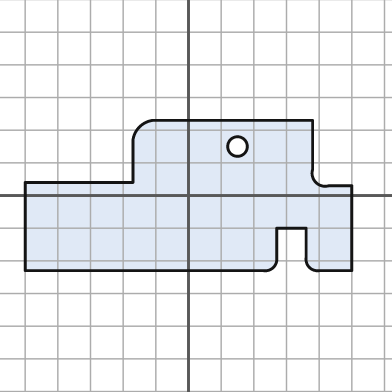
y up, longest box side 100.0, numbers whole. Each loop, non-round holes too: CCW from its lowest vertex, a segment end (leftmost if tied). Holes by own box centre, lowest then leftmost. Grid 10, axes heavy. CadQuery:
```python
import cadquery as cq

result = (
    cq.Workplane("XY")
    .moveTo(-50.0, -23.0)
    .lineTo(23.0, -23.0)
    .threePointArc((26.0, -22.0), (27.0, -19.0))
    .lineTo(27.0, -10.0)
    .lineTo(36.0, -10.0)
    .lineTo(36.0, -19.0)
    .threePointArc((37.0, -22.0), (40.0, -23.0))
    .lineTo(50.0, -23.0)
    .lineTo(50.0, 3.0)
    .lineTo(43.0, 3.0)
    .threePointArc((39.0, 4.0), (38.0, 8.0))
    .lineTo(38.0, 23.0)
    .lineTo(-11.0, 23.0)
    .threePointArc((-15.0, 21.0), (-17.0, 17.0))
    .lineTo(-17.0, 4.0)
    .lineTo(-50.0, 4.0)
    .close()
    .moveTo(15.0, 15.0)
    .circle(3.0)
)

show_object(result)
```